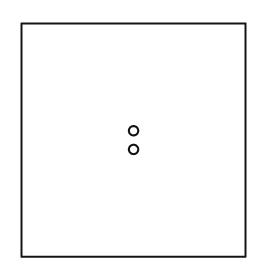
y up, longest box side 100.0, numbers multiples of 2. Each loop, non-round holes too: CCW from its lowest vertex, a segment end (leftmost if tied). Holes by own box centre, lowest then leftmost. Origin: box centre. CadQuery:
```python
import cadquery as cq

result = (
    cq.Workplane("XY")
    .moveTo(-48.0, -50.0)
    .lineTo(48.0, -50.0)
    .lineTo(48.0, 50.0)
    .lineTo(-48.0, 50.0)
    .close()
    .moveTo(0.0, -4.0)
    .circle(2.0)
    .moveTo(0.0, 4.0)
    .circle(2.0)
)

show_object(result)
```